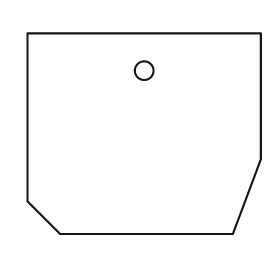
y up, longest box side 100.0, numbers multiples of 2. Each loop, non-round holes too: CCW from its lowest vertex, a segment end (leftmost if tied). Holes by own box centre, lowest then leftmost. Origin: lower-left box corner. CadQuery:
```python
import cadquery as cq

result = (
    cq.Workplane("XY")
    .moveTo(14.0, 0.0)
    .lineTo(88.0, 0.0)
    .lineTo(100.0, 32.0)
    .lineTo(100.0, 86.0)
    .lineTo(0.0, 86.0)
    .lineTo(0.0, 14.0)
    .close()
    .moveTo(50.0, 70.0)
    .circle(4.0)
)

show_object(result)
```